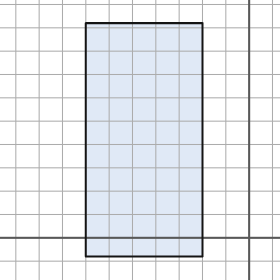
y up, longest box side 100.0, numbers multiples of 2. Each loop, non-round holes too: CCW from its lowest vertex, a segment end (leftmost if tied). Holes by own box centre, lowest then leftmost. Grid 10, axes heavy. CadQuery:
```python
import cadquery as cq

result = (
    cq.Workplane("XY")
    .moveTo(-70.0, -8.0)
    .lineTo(-20.0, -8.0)
    .lineTo(-20.0, 92.0)
    .lineTo(-70.0, 92.0)
    .close()
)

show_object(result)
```